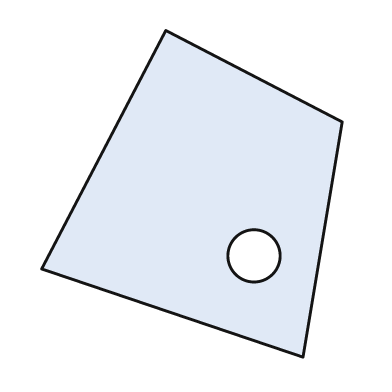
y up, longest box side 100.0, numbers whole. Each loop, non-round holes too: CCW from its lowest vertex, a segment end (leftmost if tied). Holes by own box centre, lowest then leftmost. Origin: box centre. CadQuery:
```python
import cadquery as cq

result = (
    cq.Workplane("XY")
    .moveTo(34.0, -50.0)
    .lineTo(46.0, 22.0)
    .lineTo(-8.0, 50.0)
    .lineTo(-46.0, -23.0)
    .close()
    .moveTo(19.0, -19.0)
    .circle(8.0)
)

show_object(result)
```